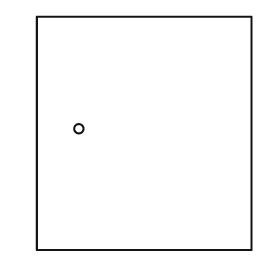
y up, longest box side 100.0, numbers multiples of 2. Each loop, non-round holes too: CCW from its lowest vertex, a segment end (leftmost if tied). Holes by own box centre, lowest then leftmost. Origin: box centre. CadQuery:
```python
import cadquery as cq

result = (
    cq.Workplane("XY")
    .moveTo(-46.0, -50.0)
    .lineTo(46.0, -50.0)
    .lineTo(46.0, 50.0)
    .lineTo(-46.0, 50.0)
    .close()
    .moveTo(-28.0, 2.0)
    .circle(2.0)
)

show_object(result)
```